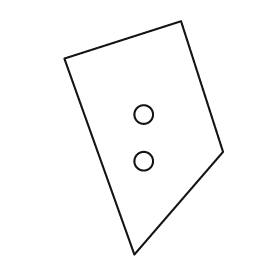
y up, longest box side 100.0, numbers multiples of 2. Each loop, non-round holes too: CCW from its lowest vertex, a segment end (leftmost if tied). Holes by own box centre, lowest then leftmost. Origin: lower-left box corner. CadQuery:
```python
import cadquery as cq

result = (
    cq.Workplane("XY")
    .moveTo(30.0, 0.0)
    .lineTo(68.0, 44.0)
    .lineTo(50.0, 100.0)
    .lineTo(0.0, 84.0)
    .close()
    .moveTo(34.0, 40.0)
    .circle(4.0)
    .moveTo(34.0, 60.0)
    .circle(4.0)
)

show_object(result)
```